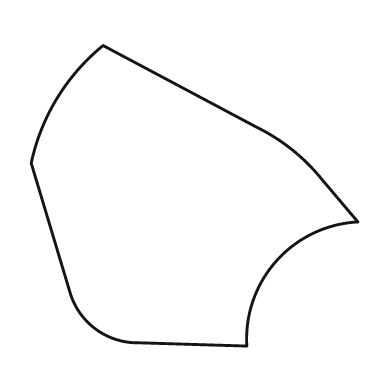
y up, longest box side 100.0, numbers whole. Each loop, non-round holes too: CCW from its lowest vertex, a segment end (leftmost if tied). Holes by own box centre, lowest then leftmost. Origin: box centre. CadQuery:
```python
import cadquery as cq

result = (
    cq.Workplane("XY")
    .moveTo(16.0, -46.0)
    .threePointArc((25.0, -20.0), (50.0, -8.0))
    .lineTo(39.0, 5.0)
    .threePointArc((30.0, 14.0), (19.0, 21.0))
    .lineTo(-28.0, 46.0)
    .threePointArc((-42.0, 30.0), (-50.0, 10.0))
    .lineTo(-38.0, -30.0)
    .threePointArc((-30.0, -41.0), (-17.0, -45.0))
    .close()
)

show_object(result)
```